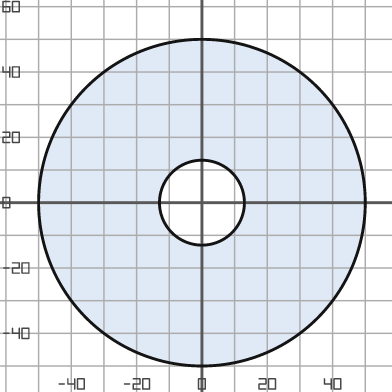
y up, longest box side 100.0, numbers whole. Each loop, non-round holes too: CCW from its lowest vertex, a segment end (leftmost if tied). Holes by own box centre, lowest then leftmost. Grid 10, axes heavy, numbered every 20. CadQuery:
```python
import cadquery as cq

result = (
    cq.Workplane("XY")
    .moveTo(0.0, 0.0)
    .circle(50.0)
    .moveTo(0.0, 0.0)
    .circle(13.0)
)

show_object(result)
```